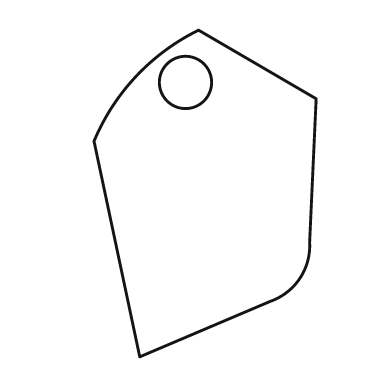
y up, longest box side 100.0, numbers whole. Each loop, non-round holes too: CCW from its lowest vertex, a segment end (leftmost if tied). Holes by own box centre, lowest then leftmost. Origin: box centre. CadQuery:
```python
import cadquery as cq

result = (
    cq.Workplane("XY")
    .moveTo(-20.0, -50.0)
    .lineTo(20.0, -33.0)
    .threePointArc((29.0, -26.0), (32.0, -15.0))
    .lineTo(34.0, 29.0)
    .lineTo(-2.0, 50.0)
    .threePointArc((-21.0, 36.0), (-34.0, 16.0))
    .close()
    .moveTo(-6.0, 34.0)
    .circle(8.0)
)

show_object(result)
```